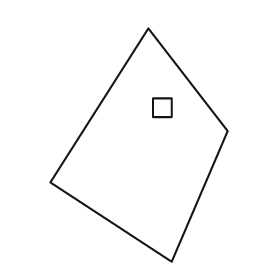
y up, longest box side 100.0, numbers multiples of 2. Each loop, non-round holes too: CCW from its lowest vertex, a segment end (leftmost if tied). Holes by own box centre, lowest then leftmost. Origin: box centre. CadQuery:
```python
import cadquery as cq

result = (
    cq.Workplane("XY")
    .moveTo(14.0, -50.0)
    .lineTo(38.0, 6.0)
    .lineTo(4.0, 50.0)
    .lineTo(-38.0, -16.0)
    .close()
    .moveTo(6.0, 12.0)
    .lineTo(14.0, 12.0)
    .lineTo(14.0, 20.0)
    .lineTo(6.0, 20.0)
    .close()
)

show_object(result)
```